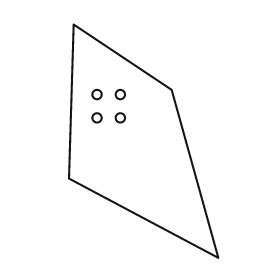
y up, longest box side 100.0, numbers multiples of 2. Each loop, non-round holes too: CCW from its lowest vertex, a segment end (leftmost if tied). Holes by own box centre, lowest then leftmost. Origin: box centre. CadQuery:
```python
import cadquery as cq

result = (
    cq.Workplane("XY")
    .moveTo(32.0, -50.0)
    .lineTo(12.0, 22.0)
    .lineTo(-30.0, 50.0)
    .lineTo(-32.0, -16.0)
    .close()
    .moveTo(-20.0, 10.0)
    .circle(2.0)
    .moveTo(-10.0, 10.0)
    .circle(2.0)
    .moveTo(-20.0, 20.0)
    .circle(2.0)
    .moveTo(-10.0, 20.0)
    .circle(2.0)
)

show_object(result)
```